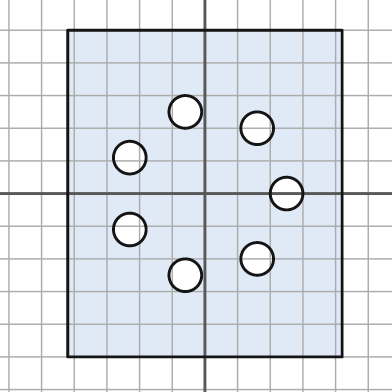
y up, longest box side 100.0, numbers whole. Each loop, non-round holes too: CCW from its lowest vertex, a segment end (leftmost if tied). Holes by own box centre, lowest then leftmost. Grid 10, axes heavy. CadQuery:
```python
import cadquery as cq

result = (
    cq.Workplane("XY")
    .moveTo(-42.0, -50.0)
    .lineTo(42.0, -50.0)
    .lineTo(42.0, 50.0)
    .lineTo(-42.0, 50.0)
    .close()
    .moveTo(-6.0, -25.0)
    .circle(5.0)
    .moveTo(16.0, -20.0)
    .circle(5.0)
    .moveTo(-23.0, -11.0)
    .circle(5.0)
    .moveTo(25.0, 0.0)
    .circle(5.0)
    .moveTo(-23.0, 11.0)
    .circle(5.0)
    .moveTo(16.0, 20.0)
    .circle(5.0)
    .moveTo(-6.0, 25.0)
    .circle(5.0)
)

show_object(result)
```